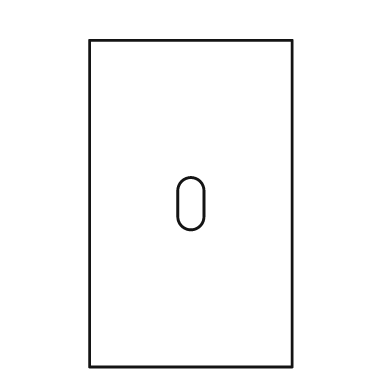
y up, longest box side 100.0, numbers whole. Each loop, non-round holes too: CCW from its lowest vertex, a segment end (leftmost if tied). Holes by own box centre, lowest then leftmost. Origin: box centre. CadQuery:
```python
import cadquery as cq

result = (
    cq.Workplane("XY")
    .moveTo(-31.0, -50.0)
    .lineTo(31.0, -50.0)
    .lineTo(31.0, 50.0)
    .lineTo(-31.0, 50.0)
    .close()
    .moveTo(-4.0, -4.0)
    .threePointArc((0.0, -8.0), (4.0, -4.0))
    .lineTo(4.0, 4.0)
    .threePointArc((0.0, 8.0), (-4.0, 4.0))
    .close()
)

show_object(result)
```